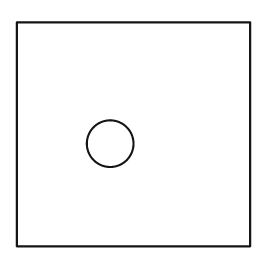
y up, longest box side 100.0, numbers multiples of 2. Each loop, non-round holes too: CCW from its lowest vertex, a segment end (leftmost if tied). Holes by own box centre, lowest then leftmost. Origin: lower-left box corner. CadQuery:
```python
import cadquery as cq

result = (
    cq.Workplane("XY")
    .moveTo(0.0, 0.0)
    .lineTo(100.0, 0.0)
    .lineTo(100.0, 96.0)
    .lineTo(0.0, 96.0)
    .close()
    .moveTo(40.0, 44.0)
    .circle(10.0)
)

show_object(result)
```